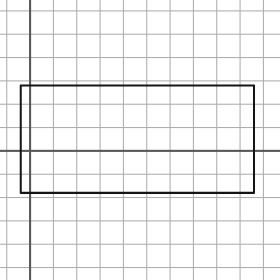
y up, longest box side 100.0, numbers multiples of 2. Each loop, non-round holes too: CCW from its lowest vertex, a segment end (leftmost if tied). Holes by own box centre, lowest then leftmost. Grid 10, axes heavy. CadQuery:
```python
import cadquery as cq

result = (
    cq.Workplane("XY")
    .moveTo(-4.0, -18.0)
    .lineTo(96.0, -18.0)
    .lineTo(96.0, 28.0)
    .lineTo(-4.0, 28.0)
    .close()
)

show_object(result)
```